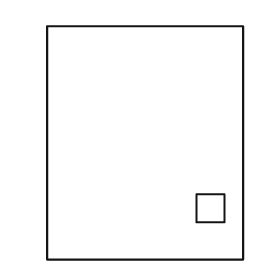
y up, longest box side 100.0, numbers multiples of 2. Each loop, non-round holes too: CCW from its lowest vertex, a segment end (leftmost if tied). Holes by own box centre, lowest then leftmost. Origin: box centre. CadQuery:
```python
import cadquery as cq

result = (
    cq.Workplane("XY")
    .moveTo(-42.0, -50.0)
    .lineTo(42.0, -50.0)
    .lineTo(42.0, 50.0)
    .lineTo(-42.0, 50.0)
    .close()
    .moveTo(22.0, -34.0)
    .lineTo(34.0, -34.0)
    .lineTo(34.0, -22.0)
    .lineTo(22.0, -22.0)
    .close()
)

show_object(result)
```